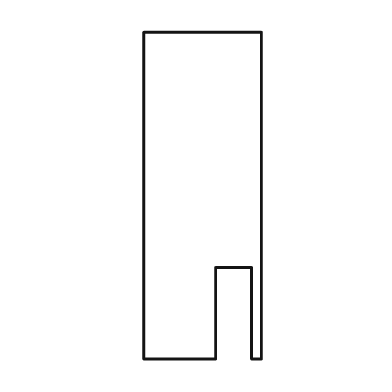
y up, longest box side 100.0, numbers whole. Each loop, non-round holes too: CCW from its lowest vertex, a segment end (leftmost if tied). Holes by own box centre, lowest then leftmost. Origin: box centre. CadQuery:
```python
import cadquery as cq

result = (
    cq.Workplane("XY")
    .moveTo(-18.0, -50.0)
    .lineTo(4.0, -50.0)
    .lineTo(4.0, -22.0)
    .lineTo(15.0, -22.0)
    .lineTo(15.0, -50.0)
    .lineTo(18.0, -50.0)
    .lineTo(18.0, 50.0)
    .lineTo(-18.0, 50.0)
    .close()
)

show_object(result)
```